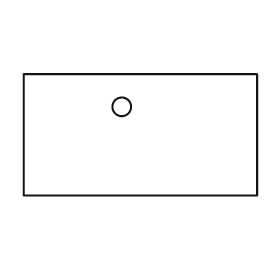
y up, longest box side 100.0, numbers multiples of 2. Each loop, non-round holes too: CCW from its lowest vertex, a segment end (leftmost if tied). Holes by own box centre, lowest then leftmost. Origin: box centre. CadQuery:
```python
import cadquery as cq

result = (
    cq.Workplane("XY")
    .moveTo(-50.0, -26.0)
    .lineTo(50.0, -26.0)
    .lineTo(50.0, 26.0)
    .lineTo(-50.0, 26.0)
    .close()
    .moveTo(-8.0, 12.0)
    .circle(4.0)
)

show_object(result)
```